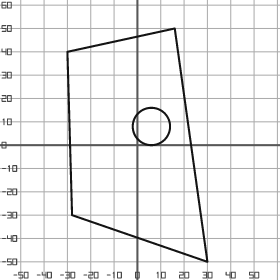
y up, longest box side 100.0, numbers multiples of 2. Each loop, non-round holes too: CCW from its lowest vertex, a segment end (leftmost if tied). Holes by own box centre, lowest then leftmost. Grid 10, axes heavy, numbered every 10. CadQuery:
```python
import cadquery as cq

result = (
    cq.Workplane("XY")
    .moveTo(30.0, -50.0)
    .lineTo(16.0, 50.0)
    .lineTo(-30.0, 40.0)
    .lineTo(-28.0, -30.0)
    .close()
    .moveTo(6.0, 8.0)
    .circle(8.0)
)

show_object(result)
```